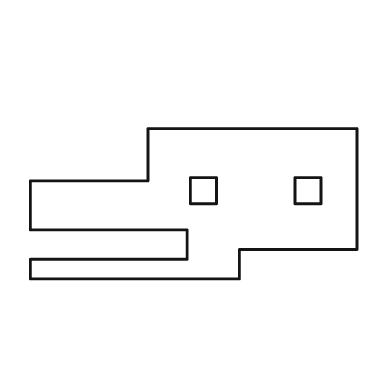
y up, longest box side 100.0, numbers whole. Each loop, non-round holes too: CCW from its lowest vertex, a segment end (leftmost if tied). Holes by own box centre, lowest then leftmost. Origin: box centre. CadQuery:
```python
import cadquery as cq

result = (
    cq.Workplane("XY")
    .moveTo(-50.0, -23.0)
    .lineTo(14.0, -23.0)
    .lineTo(14.0, -14.0)
    .lineTo(50.0, -14.0)
    .lineTo(50.0, 23.0)
    .lineTo(-14.0, 23.0)
    .lineTo(-14.0, 7.0)
    .lineTo(-50.0, 7.0)
    .lineTo(-50.0, -8.0)
    .lineTo(-2.0, -8.0)
    .lineTo(-2.0, -17.0)
    .lineTo(-50.0, -17.0)
    .close()
    .moveTo(-1.0, 0.0)
    .lineTo(7.0, 0.0)
    .lineTo(7.0, 8.0)
    .lineTo(-1.0, 8.0)
    .close()
    .moveTo(31.0, 0.0)
    .lineTo(39.0, 0.0)
    .lineTo(39.0, 8.0)
    .lineTo(31.0, 8.0)
    .close()
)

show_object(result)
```